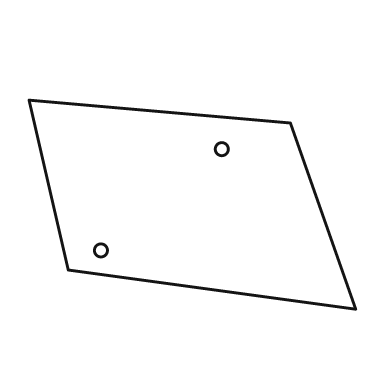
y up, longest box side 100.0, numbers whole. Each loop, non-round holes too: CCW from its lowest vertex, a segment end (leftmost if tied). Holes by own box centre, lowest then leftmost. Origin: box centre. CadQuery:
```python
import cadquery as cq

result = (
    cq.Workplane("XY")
    .moveTo(50.0, -32.0)
    .lineTo(30.0, 25.0)
    .lineTo(-50.0, 32.0)
    .lineTo(-38.0, -20.0)
    .close()
    .moveTo(-28.0, -14.0)
    .circle(2.0)
    .moveTo(9.0, 17.0)
    .circle(2.0)
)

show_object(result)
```